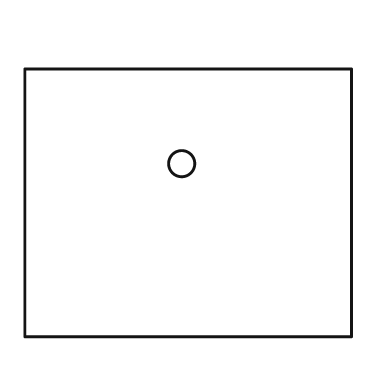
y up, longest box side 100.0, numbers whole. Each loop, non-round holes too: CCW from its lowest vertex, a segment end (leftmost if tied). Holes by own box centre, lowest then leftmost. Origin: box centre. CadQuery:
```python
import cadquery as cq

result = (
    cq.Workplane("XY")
    .moveTo(-50.0, -41.0)
    .lineTo(50.0, -41.0)
    .lineTo(50.0, 41.0)
    .lineTo(-50.0, 41.0)
    .close()
    .moveTo(-2.0, 12.0)
    .circle(4.0)
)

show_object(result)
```